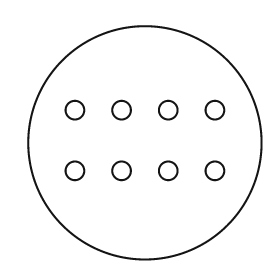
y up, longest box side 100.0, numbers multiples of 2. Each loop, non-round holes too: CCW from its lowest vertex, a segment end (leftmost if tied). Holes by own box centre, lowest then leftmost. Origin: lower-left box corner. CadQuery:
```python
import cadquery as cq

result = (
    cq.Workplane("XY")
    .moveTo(50.0, 50.0)
    .circle(50.0)
    .moveTo(20.0, 38.0)
    .circle(4.0)
    .moveTo(40.0, 38.0)
    .circle(4.0)
    .moveTo(60.0, 38.0)
    .circle(4.0)
    .moveTo(80.0, 38.0)
    .circle(4.0)
    .moveTo(20.0, 64.0)
    .circle(4.0)
    .moveTo(40.0, 64.0)
    .circle(4.0)
    .moveTo(60.0, 64.0)
    .circle(4.0)
    .moveTo(80.0, 64.0)
    .circle(4.0)
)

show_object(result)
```